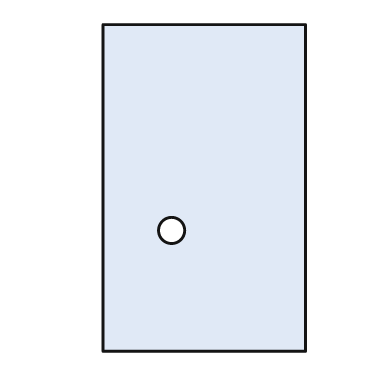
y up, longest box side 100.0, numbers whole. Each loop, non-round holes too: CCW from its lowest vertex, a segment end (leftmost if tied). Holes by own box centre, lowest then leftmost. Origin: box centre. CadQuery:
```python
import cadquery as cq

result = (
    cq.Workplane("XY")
    .moveTo(-31.0, -50.0)
    .lineTo(31.0, -50.0)
    .lineTo(31.0, 50.0)
    .lineTo(-31.0, 50.0)
    .close()
    .moveTo(-10.0, -13.0)
    .circle(4.0)
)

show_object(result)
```